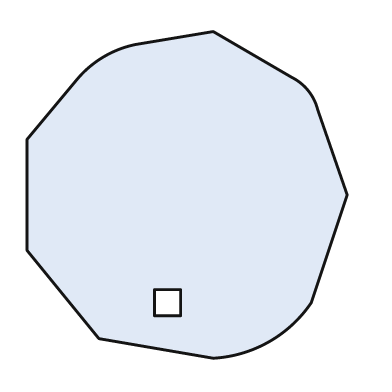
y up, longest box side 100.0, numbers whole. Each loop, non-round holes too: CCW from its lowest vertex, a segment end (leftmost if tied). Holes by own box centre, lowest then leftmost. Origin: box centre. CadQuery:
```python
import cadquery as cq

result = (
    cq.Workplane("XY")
    .moveTo(8.0, -50.0)
    .threePointArc((25.0, -45.0), (38.0, -33.0))
    .lineTo(49.0, 0.0)
    .lineTo(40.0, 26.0)
    .threePointArc((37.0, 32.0), (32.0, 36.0))
    .lineTo(8.0, 50.0)
    .lineTo(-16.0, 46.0)
    .threePointArc((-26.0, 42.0), (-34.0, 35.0))
    .lineTo(-49.0, 17.0)
    .lineTo(-49.0, -17.0)
    .lineTo(-27.0, -44.0)
    .close()
    .moveTo(-10.0, -37.0)
    .lineTo(-2.0, -37.0)
    .lineTo(-2.0, -29.0)
    .lineTo(-10.0, -29.0)
    .close()
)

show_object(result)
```